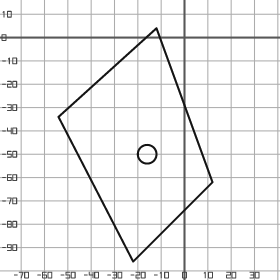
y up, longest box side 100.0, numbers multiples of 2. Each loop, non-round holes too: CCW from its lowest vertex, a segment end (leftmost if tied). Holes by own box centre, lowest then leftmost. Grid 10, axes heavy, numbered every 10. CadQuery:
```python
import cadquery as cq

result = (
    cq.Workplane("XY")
    .moveTo(-22.0, -96.0)
    .lineTo(12.0, -62.0)
    .lineTo(-12.0, 4.0)
    .lineTo(-54.0, -34.0)
    .close()
    .moveTo(-16.0, -50.0)
    .circle(4.0)
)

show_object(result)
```